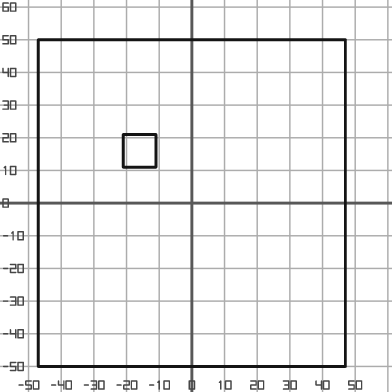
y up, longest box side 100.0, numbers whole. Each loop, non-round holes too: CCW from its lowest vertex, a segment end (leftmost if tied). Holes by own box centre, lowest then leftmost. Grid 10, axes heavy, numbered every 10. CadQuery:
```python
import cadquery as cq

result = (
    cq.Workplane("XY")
    .moveTo(-47.0, -50.0)
    .lineTo(47.0, -50.0)
    .lineTo(47.0, 50.0)
    .lineTo(-47.0, 50.0)
    .close()
    .moveTo(-21.0, 11.0)
    .lineTo(-11.0, 11.0)
    .lineTo(-11.0, 21.0)
    .lineTo(-21.0, 21.0)
    .close()
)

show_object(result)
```